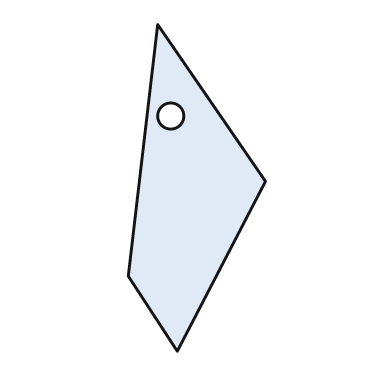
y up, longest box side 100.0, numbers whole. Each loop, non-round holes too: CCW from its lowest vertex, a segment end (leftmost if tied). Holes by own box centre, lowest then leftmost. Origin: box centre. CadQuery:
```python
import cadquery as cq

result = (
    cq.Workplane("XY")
    .moveTo(-6.0, -50.0)
    .lineTo(21.0, 2.0)
    .lineTo(-12.0, 50.0)
    .lineTo(-21.0, -27.0)
    .close()
    .moveTo(-8.0, 22.0)
    .circle(4.0)
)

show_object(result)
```